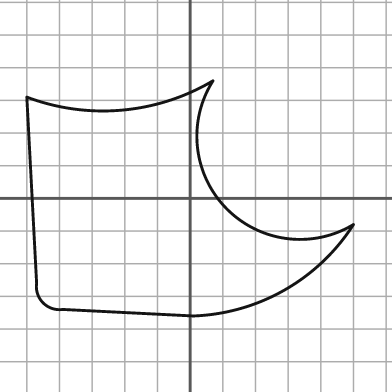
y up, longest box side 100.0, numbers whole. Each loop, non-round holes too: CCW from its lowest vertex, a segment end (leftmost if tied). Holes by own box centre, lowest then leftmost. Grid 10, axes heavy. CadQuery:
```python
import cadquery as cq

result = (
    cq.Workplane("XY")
    .moveTo(1.0, -36.0)
    .threePointArc((29.0, -28.0), (50.0, -8.0))
    .threePointArc((11.0, -3.0), (7.0, 36.0))
    .threePointArc((-21.0, 27.0), (-50.0, 31.0))
    .lineTo(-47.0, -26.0)
    .threePointArc((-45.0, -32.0), (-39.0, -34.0))
    .close()
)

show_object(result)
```